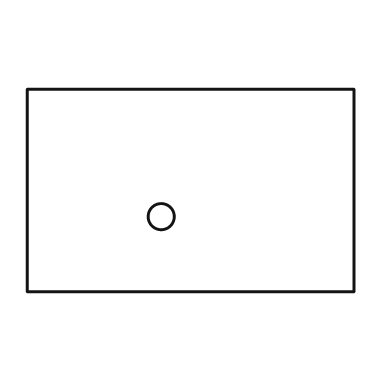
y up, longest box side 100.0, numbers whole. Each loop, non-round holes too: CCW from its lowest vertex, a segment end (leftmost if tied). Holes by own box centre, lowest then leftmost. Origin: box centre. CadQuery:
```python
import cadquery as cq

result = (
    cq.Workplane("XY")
    .moveTo(-50.0, -31.0)
    .lineTo(50.0, -31.0)
    .lineTo(50.0, 31.0)
    .lineTo(-50.0, 31.0)
    .close()
    .moveTo(-9.0, -8.0)
    .circle(4.0)
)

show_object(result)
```